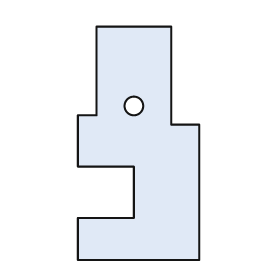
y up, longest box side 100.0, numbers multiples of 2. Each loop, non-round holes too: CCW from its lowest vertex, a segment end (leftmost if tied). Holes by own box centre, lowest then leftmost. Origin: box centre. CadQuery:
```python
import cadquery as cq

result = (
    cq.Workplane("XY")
    .moveTo(-26.0, -50.0)
    .lineTo(26.0, -50.0)
    .lineTo(26.0, 8.0)
    .lineTo(14.0, 8.0)
    .lineTo(14.0, 50.0)
    .lineTo(-18.0, 50.0)
    .lineTo(-18.0, 12.0)
    .lineTo(-26.0, 12.0)
    .lineTo(-26.0, -10.0)
    .lineTo(-2.0, -10.0)
    .lineTo(-2.0, -32.0)
    .lineTo(-26.0, -32.0)
    .close()
    .moveTo(-2.0, 16.0)
    .circle(4.0)
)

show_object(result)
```